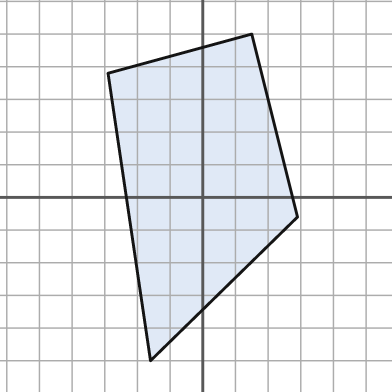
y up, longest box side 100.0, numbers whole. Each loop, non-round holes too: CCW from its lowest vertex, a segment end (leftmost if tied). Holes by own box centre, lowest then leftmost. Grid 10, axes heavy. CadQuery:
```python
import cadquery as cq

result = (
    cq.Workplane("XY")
    .moveTo(-16.0, -50.0)
    .lineTo(29.0, -6.0)
    .lineTo(15.0, 50.0)
    .lineTo(-29.0, 38.0)
    .close()
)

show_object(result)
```